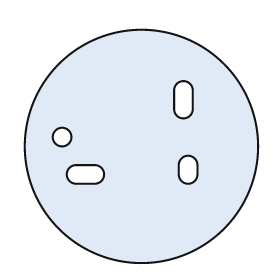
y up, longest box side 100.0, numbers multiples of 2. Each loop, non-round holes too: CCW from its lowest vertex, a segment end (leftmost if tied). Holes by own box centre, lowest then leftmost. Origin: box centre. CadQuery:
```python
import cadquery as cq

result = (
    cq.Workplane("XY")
    .moveTo(0.0, 0.0)
    .circle(50.0)
    .moveTo(-28.0, -16.0)
    .lineTo(-20.0, -16.0)
    .threePointArc((-16.0, -12.0), (-20.0, -8.0))
    .lineTo(-28.0, -8.0)
    .threePointArc((-32.0, -12.0), (-28.0, -16.0))
    .close()
    .moveTo(16.0, -12.0)
    .threePointArc((20.0, -16.0), (24.0, -12.0))
    .lineTo(24.0, -8.0)
    .threePointArc((20.0, -4.0), (16.0, -8.0))
    .close()
    .moveTo(-34.0, 4.0)
    .circle(4.0)
    .moveTo(14.0, 16.0)
    .threePointArc((18.0, 12.0), (22.0, 16.0))
    .lineTo(22.0, 24.0)
    .threePointArc((18.0, 28.0), (14.0, 24.0))
    .close()
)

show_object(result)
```